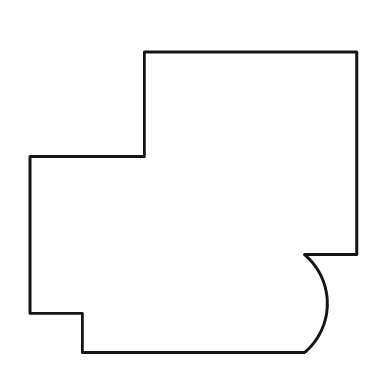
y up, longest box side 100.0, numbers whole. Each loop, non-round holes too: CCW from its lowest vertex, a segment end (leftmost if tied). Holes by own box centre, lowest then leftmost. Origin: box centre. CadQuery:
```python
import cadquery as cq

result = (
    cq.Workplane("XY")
    .moveTo(-34.0, -46.0)
    .lineTo(34.0, -46.0)
    .threePointArc((41.0, -31.0), (34.0, -16.0))
    .lineTo(50.0, -16.0)
    .lineTo(50.0, 46.0)
    .lineTo(-15.0, 46.0)
    .lineTo(-15.0, 14.0)
    .lineTo(-50.0, 14.0)
    .lineTo(-50.0, -34.0)
    .lineTo(-34.0, -34.0)
    .close()
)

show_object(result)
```